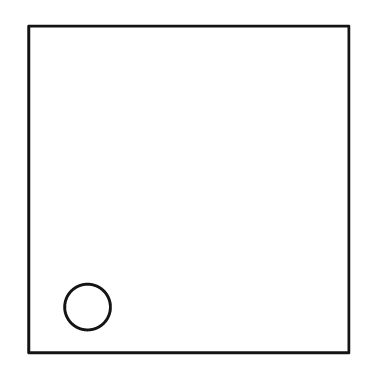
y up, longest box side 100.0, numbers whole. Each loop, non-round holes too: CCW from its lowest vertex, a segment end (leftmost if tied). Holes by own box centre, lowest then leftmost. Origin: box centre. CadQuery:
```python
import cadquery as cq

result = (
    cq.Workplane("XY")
    .moveTo(-49.0, -50.0)
    .lineTo(49.0, -50.0)
    .lineTo(49.0, 50.0)
    .lineTo(-49.0, 50.0)
    .close()
    .moveTo(-31.0, -36.0)
    .circle(7.0)
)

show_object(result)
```